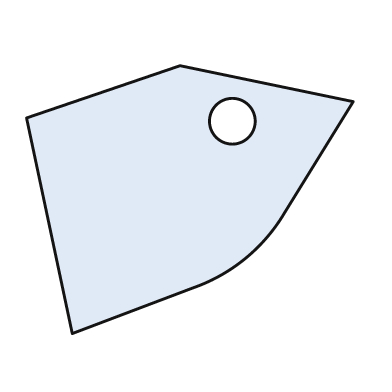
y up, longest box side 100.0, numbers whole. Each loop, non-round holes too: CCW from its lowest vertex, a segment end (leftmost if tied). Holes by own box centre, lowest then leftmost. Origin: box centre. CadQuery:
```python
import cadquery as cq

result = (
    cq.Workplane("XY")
    .moveTo(-36.0, -41.0)
    .lineTo(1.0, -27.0)
    .threePointArc((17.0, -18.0), (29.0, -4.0))
    .lineTo(50.0, 30.0)
    .lineTo(-3.0, 41.0)
    .lineTo(-50.0, 25.0)
    .close()
    .moveTo(13.0, 24.0)
    .circle(7.0)
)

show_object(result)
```